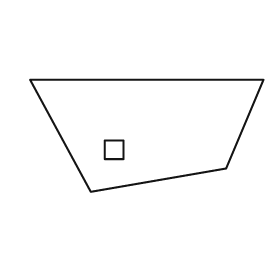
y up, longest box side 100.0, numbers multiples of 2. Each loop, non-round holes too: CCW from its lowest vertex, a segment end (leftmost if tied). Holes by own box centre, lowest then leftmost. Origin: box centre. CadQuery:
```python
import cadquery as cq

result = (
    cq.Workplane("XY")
    .moveTo(-24.0, -24.0)
    .lineTo(34.0, -14.0)
    .lineTo(50.0, 24.0)
    .lineTo(-50.0, 24.0)
    .close()
    .moveTo(-18.0, -10.0)
    .lineTo(-10.0, -10.0)
    .lineTo(-10.0, -2.0)
    .lineTo(-18.0, -2.0)
    .close()
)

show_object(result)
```